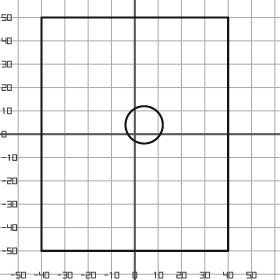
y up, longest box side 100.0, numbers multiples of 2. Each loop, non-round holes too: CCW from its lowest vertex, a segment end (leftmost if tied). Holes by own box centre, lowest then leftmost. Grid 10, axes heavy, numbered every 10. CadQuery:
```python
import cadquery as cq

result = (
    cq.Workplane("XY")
    .moveTo(-40.0, -50.0)
    .lineTo(40.0, -50.0)
    .lineTo(40.0, 50.0)
    .lineTo(-40.0, 50.0)
    .close()
    .moveTo(4.0, 4.0)
    .circle(8.0)
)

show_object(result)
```